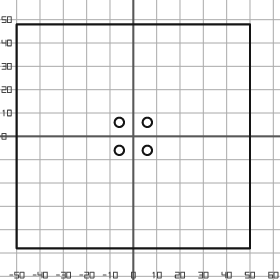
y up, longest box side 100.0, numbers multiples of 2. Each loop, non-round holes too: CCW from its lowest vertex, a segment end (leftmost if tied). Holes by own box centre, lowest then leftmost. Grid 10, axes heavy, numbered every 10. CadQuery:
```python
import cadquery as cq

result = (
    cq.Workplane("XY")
    .moveTo(-50.0, -48.0)
    .lineTo(50.0, -48.0)
    .lineTo(50.0, 48.0)
    .lineTo(-50.0, 48.0)
    .close()
    .moveTo(-6.0, -6.0)
    .circle(2.0)
    .moveTo(6.0, -6.0)
    .circle(2.0)
    .moveTo(-6.0, 6.0)
    .circle(2.0)
    .moveTo(6.0, 6.0)
    .circle(2.0)
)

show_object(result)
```